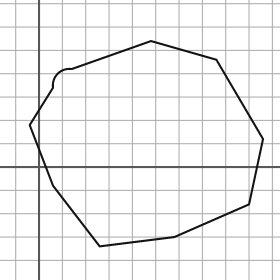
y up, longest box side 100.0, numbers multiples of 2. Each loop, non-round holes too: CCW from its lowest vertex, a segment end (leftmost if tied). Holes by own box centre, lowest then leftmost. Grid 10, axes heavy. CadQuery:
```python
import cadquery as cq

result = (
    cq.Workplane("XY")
    .moveTo(26.0, -34.0)
    .lineTo(58.0, -30.0)
    .lineTo(90.0, -16.0)
    .lineTo(96.0, 12.0)
    .lineTo(76.0, 46.0)
    .lineTo(48.0, 54.0)
    .lineTo(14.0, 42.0)
    .threePointArc((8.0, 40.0), (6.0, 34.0))
    .lineTo(-4.0, 18.0)
    .lineTo(6.0, -8.0)
    .close()
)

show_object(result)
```